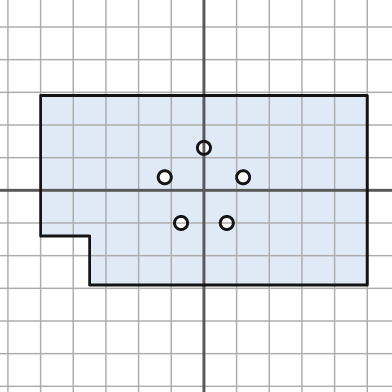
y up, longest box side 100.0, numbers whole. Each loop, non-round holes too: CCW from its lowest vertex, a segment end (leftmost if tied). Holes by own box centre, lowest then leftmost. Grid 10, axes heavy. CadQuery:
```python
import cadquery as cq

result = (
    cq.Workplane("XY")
    .moveTo(-35.0, -29.0)
    .lineTo(50.0, -29.0)
    .lineTo(50.0, 29.0)
    .lineTo(-50.0, 29.0)
    .lineTo(-50.0, -14.0)
    .lineTo(-35.0, -14.0)
    .close()
    .moveTo(-7.0, -10.0)
    .circle(2.0)
    .moveTo(7.0, -10.0)
    .circle(2.0)
    .moveTo(-12.0, 4.0)
    .circle(2.0)
    .moveTo(12.0, 4.0)
    .circle(2.0)
    .moveTo(0.0, 13.0)
    .circle(2.0)
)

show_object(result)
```